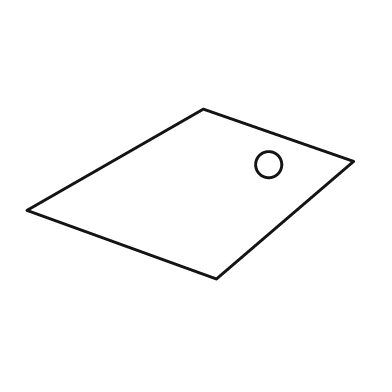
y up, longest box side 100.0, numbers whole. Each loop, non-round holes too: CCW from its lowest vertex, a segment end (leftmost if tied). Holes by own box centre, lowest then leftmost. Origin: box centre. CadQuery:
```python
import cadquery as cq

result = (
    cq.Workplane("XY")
    .moveTo(8.0, -26.0)
    .lineTo(50.0, 10.0)
    .lineTo(4.0, 26.0)
    .lineTo(-50.0, -5.0)
    .close()
    .moveTo(24.0, 9.0)
    .circle(4.0)
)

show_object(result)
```